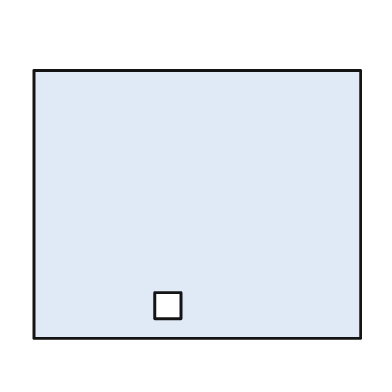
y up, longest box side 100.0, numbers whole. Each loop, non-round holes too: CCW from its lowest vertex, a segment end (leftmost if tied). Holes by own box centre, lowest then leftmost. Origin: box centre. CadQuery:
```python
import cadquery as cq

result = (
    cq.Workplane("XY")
    .moveTo(-50.0, -41.0)
    .lineTo(50.0, -41.0)
    .lineTo(50.0, 41.0)
    .lineTo(-50.0, 41.0)
    .close()
    .moveTo(-13.0, -35.0)
    .lineTo(-5.0, -35.0)
    .lineTo(-5.0, -27.0)
    .lineTo(-13.0, -27.0)
    .close()
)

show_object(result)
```